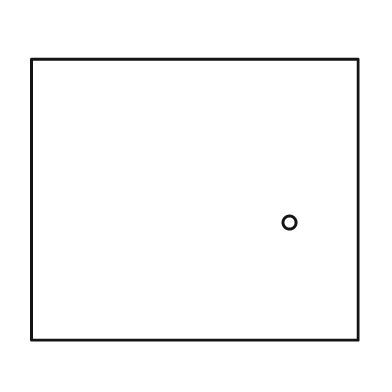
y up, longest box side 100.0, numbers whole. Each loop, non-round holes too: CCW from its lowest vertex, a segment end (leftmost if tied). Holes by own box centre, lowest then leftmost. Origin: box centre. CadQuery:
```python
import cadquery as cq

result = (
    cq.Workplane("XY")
    .moveTo(-50.0, -43.0)
    .lineTo(50.0, -43.0)
    .lineTo(50.0, 43.0)
    .lineTo(-50.0, 43.0)
    .close()
    .moveTo(29.0, -7.0)
    .circle(2.0)
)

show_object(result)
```